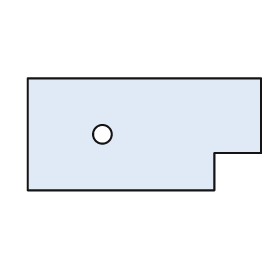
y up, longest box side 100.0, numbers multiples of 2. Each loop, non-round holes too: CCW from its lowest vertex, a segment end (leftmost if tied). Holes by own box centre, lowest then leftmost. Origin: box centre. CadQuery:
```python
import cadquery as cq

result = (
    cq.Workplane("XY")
    .moveTo(-50.0, -24.0)
    .lineTo(30.0, -24.0)
    .lineTo(30.0, -8.0)
    .lineTo(50.0, -8.0)
    .lineTo(50.0, 24.0)
    .lineTo(-50.0, 24.0)
    .close()
    .moveTo(-18.0, 0.0)
    .circle(4.0)
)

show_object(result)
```